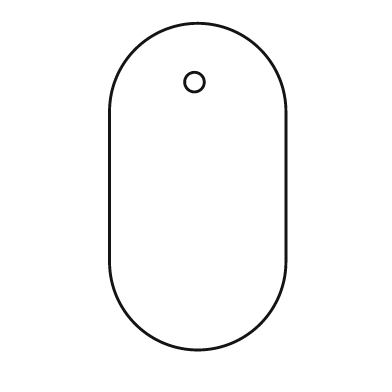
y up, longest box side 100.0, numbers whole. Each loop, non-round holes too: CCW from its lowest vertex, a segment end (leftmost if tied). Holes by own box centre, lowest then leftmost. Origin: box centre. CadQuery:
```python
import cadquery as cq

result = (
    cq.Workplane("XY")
    .moveTo(-27.0, -23.0)
    .threePointArc((0.0, -50.0), (27.0, -23.0))
    .lineTo(27.0, 23.0)
    .threePointArc((0.0, 50.0), (-27.0, 23.0))
    .close()
    .moveTo(-1.0, 32.0)
    .circle(3.0)
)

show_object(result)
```